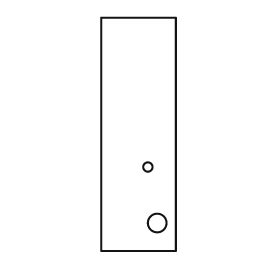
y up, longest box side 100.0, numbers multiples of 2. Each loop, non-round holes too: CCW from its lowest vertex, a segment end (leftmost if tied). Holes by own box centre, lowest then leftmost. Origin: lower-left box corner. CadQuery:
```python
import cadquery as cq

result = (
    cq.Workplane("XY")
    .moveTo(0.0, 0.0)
    .lineTo(32.0, 0.0)
    .lineTo(32.0, 100.0)
    .lineTo(0.0, 100.0)
    .close()
    .moveTo(24.0, 12.0)
    .circle(4.0)
    .moveTo(20.0, 36.0)
    .circle(2.0)
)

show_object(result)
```